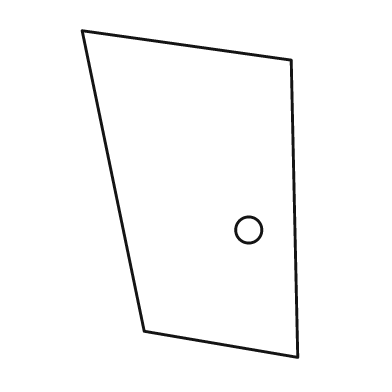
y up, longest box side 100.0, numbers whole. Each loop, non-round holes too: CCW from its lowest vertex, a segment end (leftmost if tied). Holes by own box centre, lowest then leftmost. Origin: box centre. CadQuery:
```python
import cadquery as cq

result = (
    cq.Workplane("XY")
    .moveTo(33.0, -50.0)
    .lineTo(31.0, 41.0)
    .lineTo(-33.0, 50.0)
    .lineTo(-14.0, -42.0)
    .close()
    .moveTo(18.0, -11.0)
    .circle(4.0)
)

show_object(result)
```